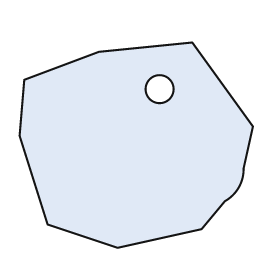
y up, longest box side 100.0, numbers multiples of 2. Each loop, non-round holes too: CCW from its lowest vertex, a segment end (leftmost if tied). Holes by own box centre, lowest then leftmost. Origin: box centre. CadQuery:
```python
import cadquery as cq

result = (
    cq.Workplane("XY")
    .moveTo(-8.0, -44.0)
    .lineTo(28.0, -36.0)
    .lineTo(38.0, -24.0)
    .threePointArc((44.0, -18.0), (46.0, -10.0))
    .lineTo(50.0, 8.0)
    .lineTo(24.0, 44.0)
    .lineTo(-16.0, 40.0)
    .lineTo(-48.0, 28.0)
    .lineTo(-50.0, 4.0)
    .lineTo(-38.0, -34.0)
    .close()
    .moveTo(10.0, 24.0)
    .circle(6.0)
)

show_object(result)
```